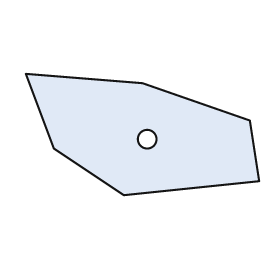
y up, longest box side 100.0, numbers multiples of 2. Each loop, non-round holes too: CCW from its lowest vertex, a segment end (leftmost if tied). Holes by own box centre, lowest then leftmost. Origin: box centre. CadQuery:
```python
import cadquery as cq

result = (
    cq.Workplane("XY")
    .moveTo(-8.0, -26.0)
    .lineTo(50.0, -20.0)
    .lineTo(46.0, 6.0)
    .lineTo(0.0, 22.0)
    .lineTo(-50.0, 26.0)
    .lineTo(-38.0, -6.0)
    .close()
    .moveTo(2.0, -2.0)
    .circle(4.0)
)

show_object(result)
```